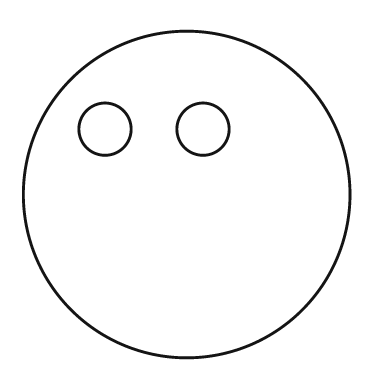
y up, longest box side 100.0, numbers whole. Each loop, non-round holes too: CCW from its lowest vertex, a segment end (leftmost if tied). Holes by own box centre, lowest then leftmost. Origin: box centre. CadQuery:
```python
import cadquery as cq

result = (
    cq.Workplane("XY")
    .moveTo(0.0, 0.0)
    .circle(50.0)
    .moveTo(-25.0, 20.0)
    .circle(8.0)
    .moveTo(5.0, 20.0)
    .circle(8.0)
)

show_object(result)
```